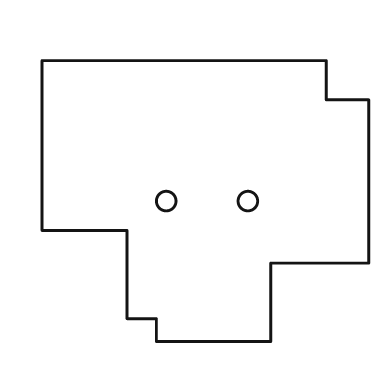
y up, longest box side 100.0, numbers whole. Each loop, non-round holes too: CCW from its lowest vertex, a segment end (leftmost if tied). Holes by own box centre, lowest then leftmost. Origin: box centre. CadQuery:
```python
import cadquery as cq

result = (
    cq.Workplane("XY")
    .moveTo(-15.0, -43.0)
    .lineTo(20.0, -43.0)
    .lineTo(20.0, -19.0)
    .lineTo(50.0, -19.0)
    .lineTo(50.0, 31.0)
    .lineTo(37.0, 31.0)
    .lineTo(37.0, 43.0)
    .lineTo(-50.0, 43.0)
    .lineTo(-50.0, -9.0)
    .lineTo(-24.0, -9.0)
    .lineTo(-24.0, -36.0)
    .lineTo(-15.0, -36.0)
    .close()
    .moveTo(-12.0, 0.0)
    .circle(3.0)
    .moveTo(13.0, 0.0)
    .circle(3.0)
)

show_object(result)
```